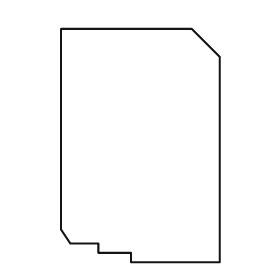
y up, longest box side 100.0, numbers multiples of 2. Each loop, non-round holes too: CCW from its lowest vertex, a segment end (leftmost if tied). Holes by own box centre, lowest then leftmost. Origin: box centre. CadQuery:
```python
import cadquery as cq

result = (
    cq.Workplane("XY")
    .moveTo(-4.0, -50.0)
    .lineTo(34.0, -50.0)
    .lineTo(34.0, 38.0)
    .lineTo(22.0, 50.0)
    .lineTo(-34.0, 50.0)
    .lineTo(-34.0, -36.0)
    .lineTo(-30.0, -42.0)
    .lineTo(-18.0, -42.0)
    .lineTo(-18.0, -46.0)
    .lineTo(-4.0, -46.0)
    .close()
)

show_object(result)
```